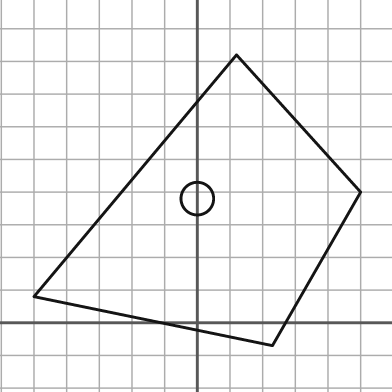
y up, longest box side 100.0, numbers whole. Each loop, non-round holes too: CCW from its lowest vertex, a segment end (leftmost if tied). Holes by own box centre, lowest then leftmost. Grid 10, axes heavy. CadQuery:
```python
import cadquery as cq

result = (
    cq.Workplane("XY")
    .moveTo(23.0, -7.0)
    .lineTo(50.0, 40.0)
    .lineTo(12.0, 82.0)
    .lineTo(-50.0, 8.0)
    .close()
    .moveTo(0.0, 38.0)
    .circle(5.0)
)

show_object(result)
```